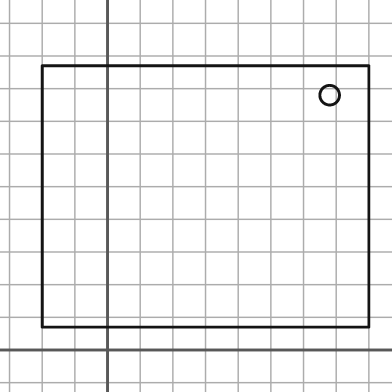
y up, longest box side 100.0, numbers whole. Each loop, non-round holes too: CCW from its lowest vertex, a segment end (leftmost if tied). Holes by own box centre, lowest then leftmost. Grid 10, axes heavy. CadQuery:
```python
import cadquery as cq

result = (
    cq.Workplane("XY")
    .moveTo(-20.0, 7.0)
    .lineTo(80.0, 7.0)
    .lineTo(80.0, 87.0)
    .lineTo(-20.0, 87.0)
    .close()
    .moveTo(68.0, 78.0)
    .circle(3.0)
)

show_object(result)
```